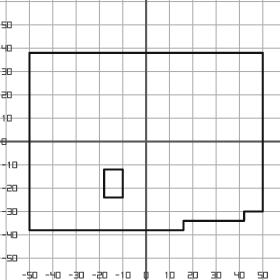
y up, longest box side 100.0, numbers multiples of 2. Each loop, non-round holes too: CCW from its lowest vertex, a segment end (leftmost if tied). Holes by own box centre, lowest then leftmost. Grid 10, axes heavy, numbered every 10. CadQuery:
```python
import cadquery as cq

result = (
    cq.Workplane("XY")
    .moveTo(-50.0, -38.0)
    .lineTo(16.0, -38.0)
    .lineTo(16.0, -34.0)
    .lineTo(42.0, -34.0)
    .lineTo(42.0, -30.0)
    .lineTo(50.0, -30.0)
    .lineTo(50.0, 38.0)
    .lineTo(-50.0, 38.0)
    .close()
    .moveTo(-18.0, -24.0)
    .lineTo(-10.0, -24.0)
    .lineTo(-10.0, -12.0)
    .lineTo(-18.0, -12.0)
    .close()
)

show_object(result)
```